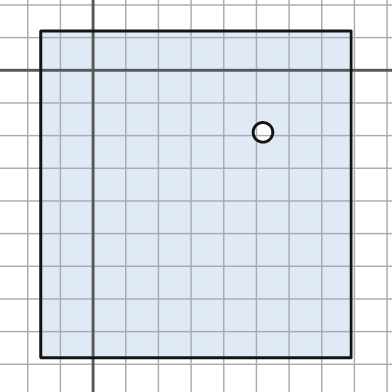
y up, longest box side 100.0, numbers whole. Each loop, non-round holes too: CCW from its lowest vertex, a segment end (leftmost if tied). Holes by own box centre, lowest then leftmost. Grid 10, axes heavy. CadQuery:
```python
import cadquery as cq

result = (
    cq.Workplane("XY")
    .moveTo(-16.0, -88.0)
    .lineTo(79.0, -88.0)
    .lineTo(79.0, 12.0)
    .lineTo(-16.0, 12.0)
    .close()
    .moveTo(52.0, -19.0)
    .circle(3.0)
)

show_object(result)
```